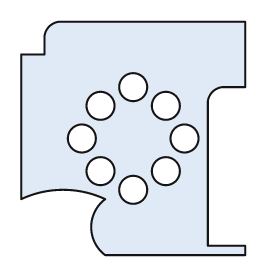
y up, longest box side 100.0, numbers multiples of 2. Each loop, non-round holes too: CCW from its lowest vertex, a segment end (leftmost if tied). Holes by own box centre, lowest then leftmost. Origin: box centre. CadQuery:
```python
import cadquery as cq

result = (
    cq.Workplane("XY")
    .moveTo(-12.0, -50.0)
    .lineTo(48.0, -50.0)
    .lineTo(48.0, -46.0)
    .lineTo(32.0, -46.0)
    .lineTo(32.0, 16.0)
    .threePointArc((34.0, 20.0), (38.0, 22.0))
    .lineTo(48.0, 22.0)
    .lineTo(48.0, 50.0)
    .lineTo(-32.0, 50.0)
    .threePointArc((-36.0, 48.0), (-38.0, 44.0))
    .lineTo(-38.0, 36.0)
    .lineTo(-48.0, 36.0)
    .lineTo(-48.0, -26.0)
    .threePointArc((-30.0, -22.0), (-12.0, -26.0))
    .threePointArc((-18.0, -38.0), (-12.0, -50.0))
    .close()
    .moveTo(0.0, -22.0)
    .circle(6.0)
    .moveTo(-14.0, -14.0)
    .circle(6.0)
    .moveTo(14.0, -14.0)
    .circle(6.0)
    .moveTo(-22.0, 0.0)
    .circle(6.0)
    .moveTo(22.0, 0.0)
    .circle(6.0)
    .moveTo(-14.0, 14.0)
    .circle(6.0)
    .moveTo(14.0, 14.0)
    .circle(6.0)
    .moveTo(0.0, 22.0)
    .circle(6.0)
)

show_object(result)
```